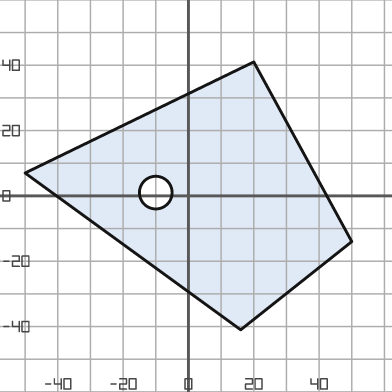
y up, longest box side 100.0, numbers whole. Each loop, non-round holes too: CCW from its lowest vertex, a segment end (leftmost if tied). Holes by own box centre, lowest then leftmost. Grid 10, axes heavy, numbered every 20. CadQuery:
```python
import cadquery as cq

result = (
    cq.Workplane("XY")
    .moveTo(16.0, -41.0)
    .lineTo(50.0, -14.0)
    .lineTo(20.0, 41.0)
    .lineTo(-50.0, 7.0)
    .close()
    .moveTo(-10.0, 1.0)
    .circle(5.0)
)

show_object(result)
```